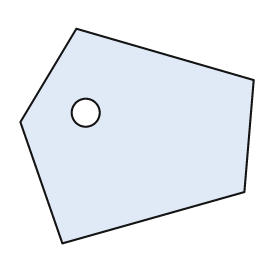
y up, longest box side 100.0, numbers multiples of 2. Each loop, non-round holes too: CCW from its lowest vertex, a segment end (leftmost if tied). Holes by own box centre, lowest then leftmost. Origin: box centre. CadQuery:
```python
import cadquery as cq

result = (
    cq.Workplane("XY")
    .moveTo(-32.0, -46.0)
    .lineTo(46.0, -24.0)
    .lineTo(50.0, 24.0)
    .lineTo(-26.0, 46.0)
    .lineTo(-50.0, 6.0)
    .close()
    .moveTo(-22.0, 10.0)
    .circle(6.0)
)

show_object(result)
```